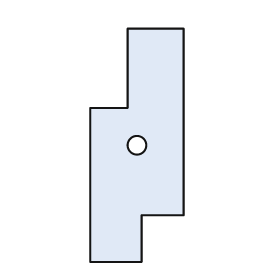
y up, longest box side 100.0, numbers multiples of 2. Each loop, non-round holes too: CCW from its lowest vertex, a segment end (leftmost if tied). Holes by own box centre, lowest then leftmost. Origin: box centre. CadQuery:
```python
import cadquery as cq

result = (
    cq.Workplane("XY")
    .moveTo(-20.0, -50.0)
    .lineTo(2.0, -50.0)
    .lineTo(2.0, -30.0)
    .lineTo(20.0, -30.0)
    .lineTo(20.0, 50.0)
    .lineTo(-4.0, 50.0)
    .lineTo(-4.0, 16.0)
    .lineTo(-20.0, 16.0)
    .close()
    .moveTo(0.0, 0.0)
    .circle(4.0)
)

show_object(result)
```